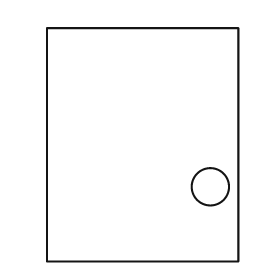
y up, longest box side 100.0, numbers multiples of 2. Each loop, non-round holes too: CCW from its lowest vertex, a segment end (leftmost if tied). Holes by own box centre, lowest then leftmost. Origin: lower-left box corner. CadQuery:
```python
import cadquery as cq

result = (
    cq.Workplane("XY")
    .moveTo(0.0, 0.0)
    .lineTo(82.0, 0.0)
    .lineTo(82.0, 100.0)
    .lineTo(0.0, 100.0)
    .close()
    .moveTo(70.0, 32.0)
    .circle(8.0)
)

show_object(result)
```